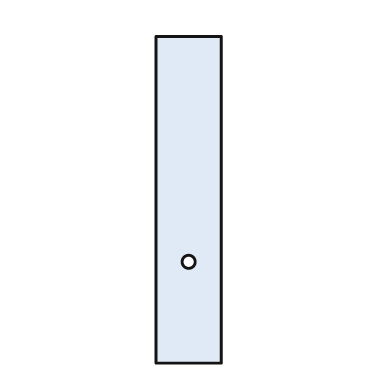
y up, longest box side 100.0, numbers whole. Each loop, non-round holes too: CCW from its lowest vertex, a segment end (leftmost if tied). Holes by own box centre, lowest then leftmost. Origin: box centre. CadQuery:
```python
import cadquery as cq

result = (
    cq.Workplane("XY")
    .moveTo(-10.0, -50.0)
    .lineTo(10.0, -50.0)
    .lineTo(10.0, 50.0)
    .lineTo(-10.0, 50.0)
    .close()
    .moveTo(0.0, -19.0)
    .circle(2.0)
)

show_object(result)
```